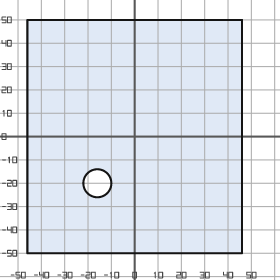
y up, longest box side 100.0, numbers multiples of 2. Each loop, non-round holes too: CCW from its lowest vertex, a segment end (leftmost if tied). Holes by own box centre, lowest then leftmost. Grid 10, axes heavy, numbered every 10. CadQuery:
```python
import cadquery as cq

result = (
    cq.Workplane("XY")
    .moveTo(-46.0, -50.0)
    .lineTo(46.0, -50.0)
    .lineTo(46.0, 50.0)
    .lineTo(-46.0, 50.0)
    .close()
    .moveTo(-16.0, -20.0)
    .circle(6.0)
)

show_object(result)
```